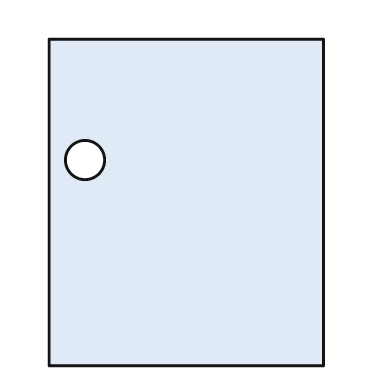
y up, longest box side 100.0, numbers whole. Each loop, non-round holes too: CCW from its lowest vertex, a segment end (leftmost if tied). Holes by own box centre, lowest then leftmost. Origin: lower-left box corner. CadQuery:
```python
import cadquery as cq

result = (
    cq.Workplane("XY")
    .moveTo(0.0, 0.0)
    .lineTo(84.0, 0.0)
    .lineTo(84.0, 100.0)
    .lineTo(0.0, 100.0)
    .close()
    .moveTo(11.0, 63.0)
    .circle(6.0)
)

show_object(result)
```